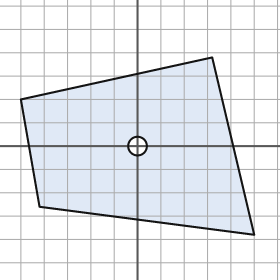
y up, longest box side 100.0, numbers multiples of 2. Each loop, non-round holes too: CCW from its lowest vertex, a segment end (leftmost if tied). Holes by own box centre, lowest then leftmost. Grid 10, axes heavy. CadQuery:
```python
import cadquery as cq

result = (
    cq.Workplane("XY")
    .moveTo(50.0, -38.0)
    .lineTo(32.0, 38.0)
    .lineTo(-50.0, 20.0)
    .lineTo(-42.0, -26.0)
    .close()
    .moveTo(0.0, 0.0)
    .circle(4.0)
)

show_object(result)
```